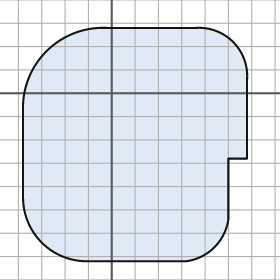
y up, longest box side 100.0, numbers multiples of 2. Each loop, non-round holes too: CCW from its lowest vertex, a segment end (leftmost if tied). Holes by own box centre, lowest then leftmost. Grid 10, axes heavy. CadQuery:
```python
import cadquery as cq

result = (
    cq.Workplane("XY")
    .moveTo(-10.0, -72.0)
    .lineTo(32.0, -72.0)
    .threePointArc((44.0, -66.0), (50.0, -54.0))
    .lineTo(50.0, -28.0)
    .lineTo(58.0, -28.0)
    .lineTo(58.0, 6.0)
    .threePointArc((52.0, 22.0), (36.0, 28.0))
    .lineTo(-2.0, 28.0)
    .threePointArc((-28.0, 18.0), (-38.0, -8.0))
    .lineTo(-38.0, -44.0)
    .threePointArc((-30.0, -64.0), (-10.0, -72.0))
    .close()
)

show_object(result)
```